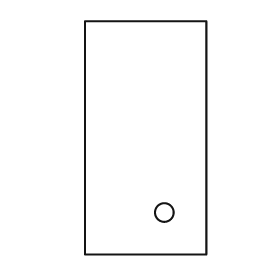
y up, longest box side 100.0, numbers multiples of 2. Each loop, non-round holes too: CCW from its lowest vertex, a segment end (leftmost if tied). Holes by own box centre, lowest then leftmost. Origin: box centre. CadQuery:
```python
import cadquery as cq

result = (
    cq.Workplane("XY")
    .moveTo(-26.0, -50.0)
    .lineTo(26.0, -50.0)
    .lineTo(26.0, 50.0)
    .lineTo(-26.0, 50.0)
    .close()
    .moveTo(8.0, -32.0)
    .circle(4.0)
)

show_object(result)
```